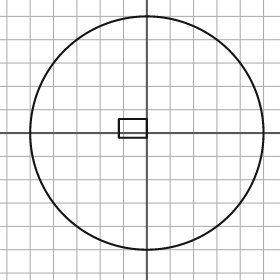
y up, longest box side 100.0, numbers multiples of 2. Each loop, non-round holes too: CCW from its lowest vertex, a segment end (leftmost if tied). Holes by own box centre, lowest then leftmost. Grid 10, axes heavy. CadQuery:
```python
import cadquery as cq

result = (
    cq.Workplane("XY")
    .moveTo(0.0, 0.0)
    .circle(50.0)
    .moveTo(-12.0, -2.0)
    .lineTo(0.0, -2.0)
    .lineTo(0.0, 6.0)
    .lineTo(-12.0, 6.0)
    .close()
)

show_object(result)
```